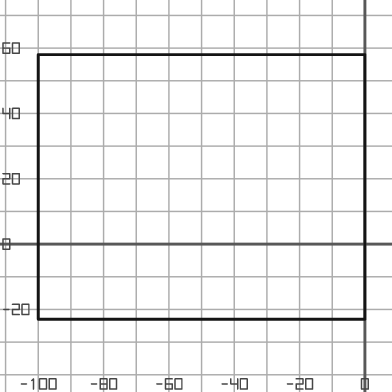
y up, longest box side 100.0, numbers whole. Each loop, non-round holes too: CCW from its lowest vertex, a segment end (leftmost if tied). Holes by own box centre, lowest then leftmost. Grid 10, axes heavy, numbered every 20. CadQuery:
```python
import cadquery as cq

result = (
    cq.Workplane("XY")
    .moveTo(-100.0, -23.0)
    .lineTo(0.0, -23.0)
    .lineTo(0.0, 58.0)
    .lineTo(-100.0, 58.0)
    .close()
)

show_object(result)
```